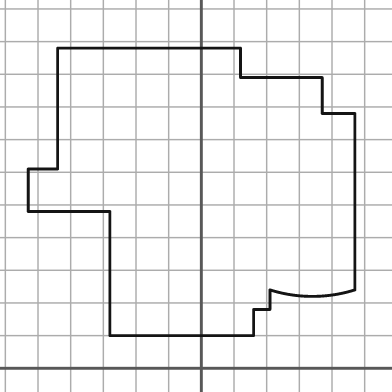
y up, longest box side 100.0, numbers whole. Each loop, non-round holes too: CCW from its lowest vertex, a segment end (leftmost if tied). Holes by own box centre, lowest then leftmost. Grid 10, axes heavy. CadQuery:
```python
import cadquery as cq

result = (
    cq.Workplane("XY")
    .moveTo(-28.0, 10.0)
    .lineTo(16.0, 10.0)
    .lineTo(16.0, 18.0)
    .lineTo(21.0, 18.0)
    .lineTo(21.0, 24.0)
    .threePointArc((34.0, 22.0), (47.0, 24.0))
    .lineTo(47.0, 78.0)
    .lineTo(37.0, 78.0)
    .lineTo(37.0, 89.0)
    .lineTo(12.0, 89.0)
    .lineTo(12.0, 98.0)
    .lineTo(-44.0, 98.0)
    .lineTo(-44.0, 61.0)
    .lineTo(-53.0, 61.0)
    .lineTo(-53.0, 48.0)
    .lineTo(-28.0, 48.0)
    .close()
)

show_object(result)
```